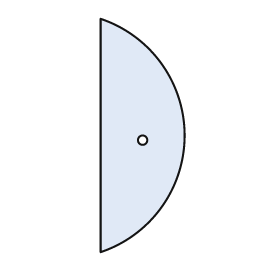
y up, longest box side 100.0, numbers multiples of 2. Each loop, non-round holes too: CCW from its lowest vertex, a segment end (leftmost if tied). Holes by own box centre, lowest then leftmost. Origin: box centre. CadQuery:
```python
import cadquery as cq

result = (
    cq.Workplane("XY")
    .moveTo(-18.0, -50.0)
    .threePointArc((18.0, 0.0), (-18.0, 50.0))
    .close()
    .moveTo(0.0, -2.0)
    .circle(2.0)
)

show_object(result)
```